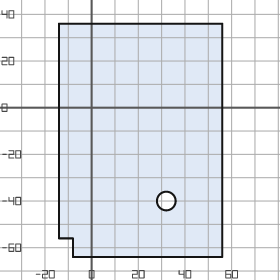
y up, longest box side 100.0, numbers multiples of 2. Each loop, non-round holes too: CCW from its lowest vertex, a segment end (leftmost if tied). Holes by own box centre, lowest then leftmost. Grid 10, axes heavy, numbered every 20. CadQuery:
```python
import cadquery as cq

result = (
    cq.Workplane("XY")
    .moveTo(-8.0, -64.0)
    .lineTo(56.0, -64.0)
    .lineTo(56.0, 36.0)
    .lineTo(-14.0, 36.0)
    .lineTo(-14.0, -56.0)
    .lineTo(-8.0, -56.0)
    .close()
    .moveTo(32.0, -40.0)
    .circle(4.0)
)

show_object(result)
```